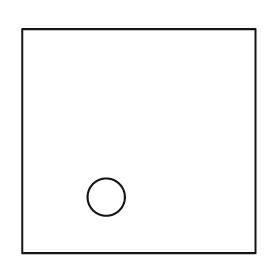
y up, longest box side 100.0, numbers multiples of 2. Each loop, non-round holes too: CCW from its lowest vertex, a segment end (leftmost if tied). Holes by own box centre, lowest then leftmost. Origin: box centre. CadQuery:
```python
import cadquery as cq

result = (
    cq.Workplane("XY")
    .moveTo(-50.0, -48.0)
    .lineTo(50.0, -48.0)
    .lineTo(50.0, 48.0)
    .lineTo(-50.0, 48.0)
    .close()
    .moveTo(-14.0, -24.0)
    .circle(8.0)
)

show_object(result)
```